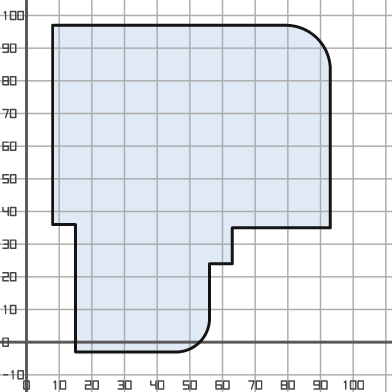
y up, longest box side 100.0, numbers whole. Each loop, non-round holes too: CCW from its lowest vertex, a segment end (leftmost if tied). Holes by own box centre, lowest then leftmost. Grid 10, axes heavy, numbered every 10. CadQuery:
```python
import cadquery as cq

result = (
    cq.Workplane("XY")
    .moveTo(15.0, -3.0)
    .lineTo(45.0, -3.0)
    .threePointArc((53.0, 0.0), (56.0, 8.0))
    .lineTo(56.0, 24.0)
    .lineTo(63.0, 24.0)
    .lineTo(63.0, 35.0)
    .lineTo(93.0, 35.0)
    .lineTo(93.0, 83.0)
    .threePointArc((89.0, 93.0), (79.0, 97.0))
    .lineTo(8.0, 97.0)
    .lineTo(8.0, 36.0)
    .lineTo(15.0, 36.0)
    .close()
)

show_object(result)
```